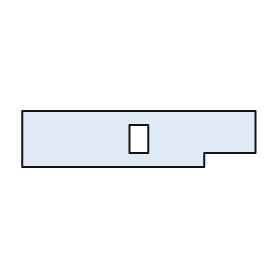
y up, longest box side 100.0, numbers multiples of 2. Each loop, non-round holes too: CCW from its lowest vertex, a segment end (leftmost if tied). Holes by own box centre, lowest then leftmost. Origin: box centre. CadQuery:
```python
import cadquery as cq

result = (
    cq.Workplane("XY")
    .moveTo(-50.0, -12.0)
    .lineTo(28.0, -12.0)
    .lineTo(28.0, -6.0)
    .lineTo(50.0, -6.0)
    .lineTo(50.0, 12.0)
    .lineTo(-50.0, 12.0)
    .close()
    .moveTo(-4.0, -6.0)
    .lineTo(4.0, -6.0)
    .lineTo(4.0, 6.0)
    .lineTo(-4.0, 6.0)
    .close()
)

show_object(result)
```